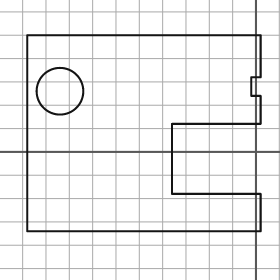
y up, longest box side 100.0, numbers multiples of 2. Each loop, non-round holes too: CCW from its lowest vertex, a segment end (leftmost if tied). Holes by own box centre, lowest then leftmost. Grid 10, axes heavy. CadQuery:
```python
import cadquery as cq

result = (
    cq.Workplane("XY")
    .moveTo(-98.0, -34.0)
    .lineTo(2.0, -34.0)
    .lineTo(2.0, -18.0)
    .lineTo(-36.0, -18.0)
    .lineTo(-36.0, 12.0)
    .lineTo(2.0, 12.0)
    .lineTo(2.0, 24.0)
    .lineTo(-2.0, 24.0)
    .lineTo(-2.0, 32.0)
    .lineTo(2.0, 32.0)
    .lineTo(2.0, 50.0)
    .lineTo(-98.0, 50.0)
    .close()
    .moveTo(-84.0, 26.0)
    .circle(10.0)
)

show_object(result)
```